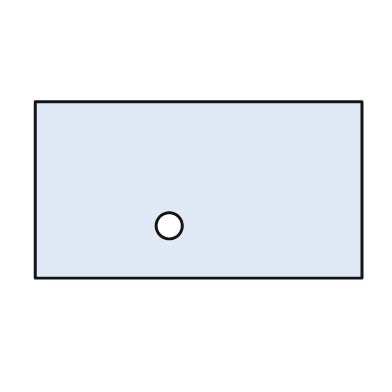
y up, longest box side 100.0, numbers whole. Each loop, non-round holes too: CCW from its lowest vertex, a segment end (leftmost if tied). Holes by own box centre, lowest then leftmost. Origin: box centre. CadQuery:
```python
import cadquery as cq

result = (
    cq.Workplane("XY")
    .moveTo(-50.0, -27.0)
    .lineTo(50.0, -27.0)
    .lineTo(50.0, 27.0)
    .lineTo(-50.0, 27.0)
    .close()
    .moveTo(-9.0, -11.0)
    .circle(4.0)
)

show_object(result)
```